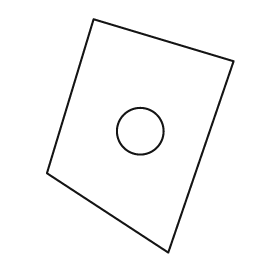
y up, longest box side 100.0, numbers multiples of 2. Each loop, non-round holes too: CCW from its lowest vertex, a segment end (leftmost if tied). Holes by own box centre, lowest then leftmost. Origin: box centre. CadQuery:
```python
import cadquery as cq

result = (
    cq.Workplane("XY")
    .moveTo(12.0, -50.0)
    .lineTo(40.0, 32.0)
    .lineTo(-20.0, 50.0)
    .lineTo(-40.0, -16.0)
    .close()
    .moveTo(0.0, 2.0)
    .circle(10.0)
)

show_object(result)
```